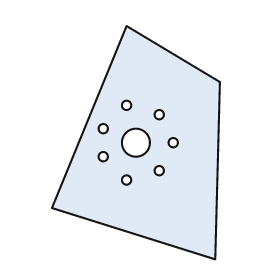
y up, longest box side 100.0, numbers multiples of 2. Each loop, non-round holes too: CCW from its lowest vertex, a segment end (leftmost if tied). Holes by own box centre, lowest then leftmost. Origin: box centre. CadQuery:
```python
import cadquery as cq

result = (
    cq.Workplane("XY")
    .moveTo(34.0, -50.0)
    .lineTo(36.0, 26.0)
    .lineTo(-4.0, 50.0)
    .lineTo(-36.0, -28.0)
    .close()
    .moveTo(-4.0, -16.0)
    .circle(2.0)
    .moveTo(10.0, -12.0)
    .circle(2.0)
    .moveTo(-14.0, -6.0)
    .circle(2.0)
    .moveTo(0.0, 0.0)
    .circle(6.0)
    .moveTo(16.0, 0.0)
    .circle(2.0)
    .moveTo(-14.0, 6.0)
    .circle(2.0)
    .moveTo(10.0, 12.0)
    .circle(2.0)
    .moveTo(-4.0, 16.0)
    .circle(2.0)
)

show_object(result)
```